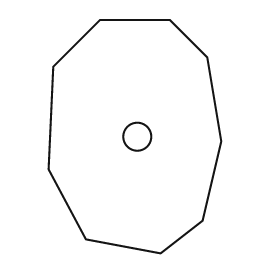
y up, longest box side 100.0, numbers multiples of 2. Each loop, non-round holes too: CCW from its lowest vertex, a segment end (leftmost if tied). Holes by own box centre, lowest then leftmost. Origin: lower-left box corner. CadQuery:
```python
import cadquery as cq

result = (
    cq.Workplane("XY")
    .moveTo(48.0, 0.0)
    .lineTo(66.0, 14.0)
    .lineTo(74.0, 48.0)
    .lineTo(68.0, 84.0)
    .lineTo(52.0, 100.0)
    .lineTo(22.0, 100.0)
    .lineTo(2.0, 80.0)
    .lineTo(0.0, 36.0)
    .lineTo(16.0, 6.0)
    .close()
    .moveTo(38.0, 50.0)
    .circle(6.0)
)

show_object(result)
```